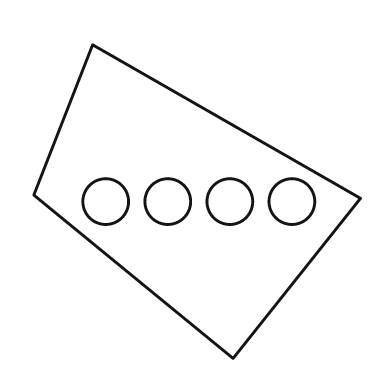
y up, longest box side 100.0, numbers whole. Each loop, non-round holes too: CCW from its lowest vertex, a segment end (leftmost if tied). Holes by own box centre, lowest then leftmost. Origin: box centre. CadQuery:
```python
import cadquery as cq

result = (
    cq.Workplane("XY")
    .moveTo(11.0, -48.0)
    .lineTo(50.0, 1.0)
    .lineTo(-32.0, 48.0)
    .lineTo(-50.0, 2.0)
    .close()
    .moveTo(-28.0, 0.0)
    .circle(7.0)
    .moveTo(-9.0, 0.0)
    .circle(7.0)
    .moveTo(10.0, 0.0)
    .circle(7.0)
    .moveTo(29.0, 0.0)
    .circle(7.0)
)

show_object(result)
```